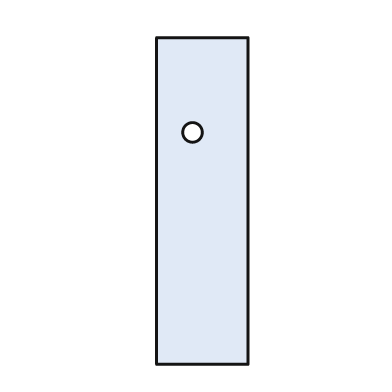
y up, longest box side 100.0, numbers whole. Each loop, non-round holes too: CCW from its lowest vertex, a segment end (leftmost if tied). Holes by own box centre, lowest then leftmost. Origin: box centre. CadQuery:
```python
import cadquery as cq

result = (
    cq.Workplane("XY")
    .moveTo(-14.0, -50.0)
    .lineTo(14.0, -50.0)
    .lineTo(14.0, 50.0)
    .lineTo(-14.0, 50.0)
    .close()
    .moveTo(-3.0, 21.0)
    .circle(3.0)
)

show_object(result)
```